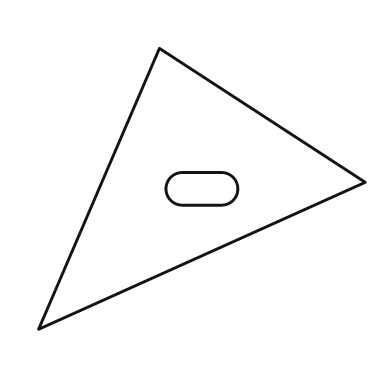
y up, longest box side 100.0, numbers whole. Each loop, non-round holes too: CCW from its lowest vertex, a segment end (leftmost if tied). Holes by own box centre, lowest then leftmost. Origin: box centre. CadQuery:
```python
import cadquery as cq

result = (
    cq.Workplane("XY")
    .moveTo(-50.0, -43.0)
    .lineTo(50.0, 2.0)
    .lineTo(-13.0, 43.0)
    .close()
    .moveTo(-6.0, -5.0)
    .lineTo(6.0, -5.0)
    .threePointArc((11.0, 0.0), (6.0, 5.0))
    .lineTo(-6.0, 5.0)
    .threePointArc((-11.0, 0.0), (-6.0, -5.0))
    .close()
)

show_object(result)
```